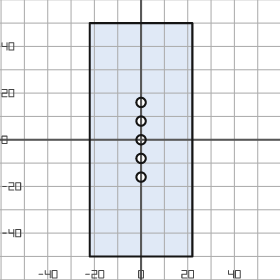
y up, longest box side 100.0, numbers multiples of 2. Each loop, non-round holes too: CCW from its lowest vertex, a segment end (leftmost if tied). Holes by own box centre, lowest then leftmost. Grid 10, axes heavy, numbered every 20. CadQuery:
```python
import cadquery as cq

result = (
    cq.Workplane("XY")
    .moveTo(-22.0, -50.0)
    .lineTo(22.0, -50.0)
    .lineTo(22.0, 50.0)
    .lineTo(-22.0, 50.0)
    .close()
    .moveTo(0.0, -16.0)
    .circle(2.0)
    .moveTo(0.0, -8.0)
    .circle(2.0)
    .moveTo(0.0, 0.0)
    .circle(2.0)
    .moveTo(0.0, 8.0)
    .circle(2.0)
    .moveTo(0.0, 16.0)
    .circle(2.0)
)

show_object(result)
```